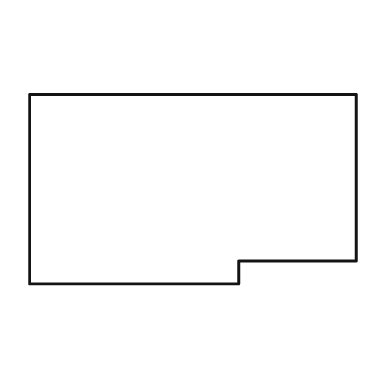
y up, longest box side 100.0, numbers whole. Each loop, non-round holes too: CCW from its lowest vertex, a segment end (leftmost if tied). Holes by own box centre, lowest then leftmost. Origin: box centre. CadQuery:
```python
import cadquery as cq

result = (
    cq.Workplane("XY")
    .moveTo(-50.0, -29.0)
    .lineTo(14.0, -29.0)
    .lineTo(14.0, -22.0)
    .lineTo(50.0, -22.0)
    .lineTo(50.0, 29.0)
    .lineTo(-50.0, 29.0)
    .close()
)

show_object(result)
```